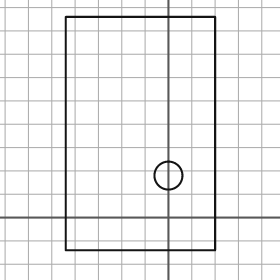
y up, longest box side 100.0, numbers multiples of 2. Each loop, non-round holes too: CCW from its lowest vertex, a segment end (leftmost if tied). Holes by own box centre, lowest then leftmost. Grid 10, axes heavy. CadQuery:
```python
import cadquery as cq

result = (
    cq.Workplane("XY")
    .moveTo(-44.0, -14.0)
    .lineTo(20.0, -14.0)
    .lineTo(20.0, 86.0)
    .lineTo(-44.0, 86.0)
    .close()
    .moveTo(0.0, 18.0)
    .circle(6.0)
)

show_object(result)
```